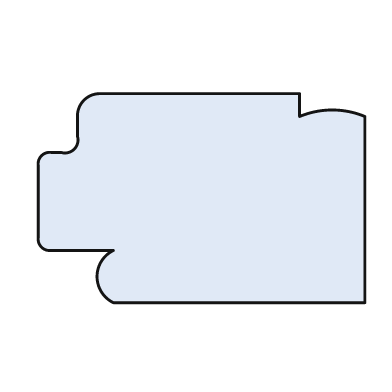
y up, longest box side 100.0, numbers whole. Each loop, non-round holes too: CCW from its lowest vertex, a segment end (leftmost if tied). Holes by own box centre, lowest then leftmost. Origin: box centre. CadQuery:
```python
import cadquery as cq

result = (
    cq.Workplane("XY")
    .moveTo(-27.0, -32.0)
    .lineTo(50.0, -32.0)
    .lineTo(50.0, 25.0)
    .threePointArc((40.0, 27.0), (30.0, 25.0))
    .lineTo(30.0, 32.0)
    .lineTo(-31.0, 32.0)
    .threePointArc((-36.0, 30.0), (-38.0, 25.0))
    .lineTo(-38.0, 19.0)
    .threePointArc((-39.0, 15.0), (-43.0, 14.0))
    .lineTo(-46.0, 14.0)
    .threePointArc((-49.0, 13.0), (-50.0, 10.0))
    .lineTo(-50.0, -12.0)
    .threePointArc((-49.0, -15.0), (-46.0, -16.0))
    .lineTo(-27.0, -16.0)
    .threePointArc((-32.0, -24.0), (-27.0, -32.0))
    .close()
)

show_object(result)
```